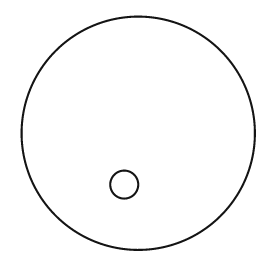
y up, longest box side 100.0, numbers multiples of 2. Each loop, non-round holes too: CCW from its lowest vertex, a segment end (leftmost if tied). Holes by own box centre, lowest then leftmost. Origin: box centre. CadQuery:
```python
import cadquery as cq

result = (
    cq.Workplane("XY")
    .moveTo(0.0, 0.0)
    .circle(50.0)
    .moveTo(-6.0, -22.0)
    .circle(6.0)
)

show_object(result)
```